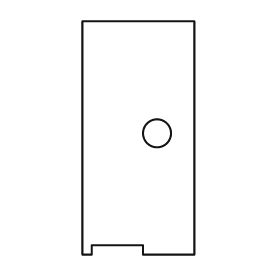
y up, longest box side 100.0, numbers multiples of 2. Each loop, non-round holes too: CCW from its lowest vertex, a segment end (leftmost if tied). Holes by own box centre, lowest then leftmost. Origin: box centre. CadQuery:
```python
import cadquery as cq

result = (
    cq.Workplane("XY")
    .moveTo(-24.0, -50.0)
    .lineTo(-20.0, -50.0)
    .lineTo(-20.0, -46.0)
    .lineTo(2.0, -46.0)
    .lineTo(2.0, -50.0)
    .lineTo(24.0, -50.0)
    .lineTo(24.0, 50.0)
    .lineTo(-24.0, 50.0)
    .close()
    .moveTo(8.0, 2.0)
    .circle(6.0)
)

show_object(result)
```